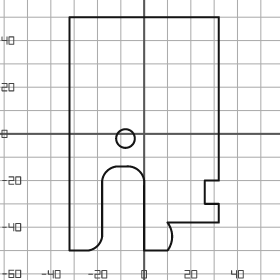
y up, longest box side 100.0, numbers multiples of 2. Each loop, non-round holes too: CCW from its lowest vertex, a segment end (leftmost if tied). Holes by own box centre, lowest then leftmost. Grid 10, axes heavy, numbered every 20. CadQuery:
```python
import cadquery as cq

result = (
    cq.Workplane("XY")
    .moveTo(-32.0, -50.0)
    .lineTo(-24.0, -50.0)
    .threePointArc((-20.0, -48.0), (-18.0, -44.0))
    .lineTo(-18.0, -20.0)
    .threePointArc((-16.0, -16.0), (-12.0, -14.0))
    .lineTo(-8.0, -14.0)
    .threePointArc((-2.0, -16.0), (0.0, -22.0))
    .lineTo(0.0, -50.0)
    .lineTo(10.0, -50.0)
    .threePointArc((12.0, -44.0), (10.0, -38.0))
    .lineTo(32.0, -38.0)
    .lineTo(32.0, -30.0)
    .lineTo(26.0, -30.0)
    .lineTo(26.0, -20.0)
    .lineTo(32.0, -20.0)
    .lineTo(32.0, 50.0)
    .lineTo(-32.0, 50.0)
    .close()
    .moveTo(-8.0, -2.0)
    .circle(4.0)
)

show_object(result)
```